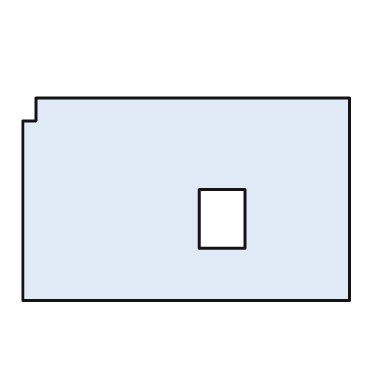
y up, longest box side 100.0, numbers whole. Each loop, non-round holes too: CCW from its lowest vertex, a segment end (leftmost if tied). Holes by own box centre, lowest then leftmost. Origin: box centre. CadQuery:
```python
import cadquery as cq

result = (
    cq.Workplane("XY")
    .moveTo(-50.0, -31.0)
    .lineTo(50.0, -31.0)
    .lineTo(50.0, 31.0)
    .lineTo(-46.0, 31.0)
    .lineTo(-46.0, 24.0)
    .lineTo(-50.0, 24.0)
    .close()
    .moveTo(4.0, -15.0)
    .lineTo(18.0, -15.0)
    .lineTo(18.0, 3.0)
    .lineTo(4.0, 3.0)
    .close()
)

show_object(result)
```